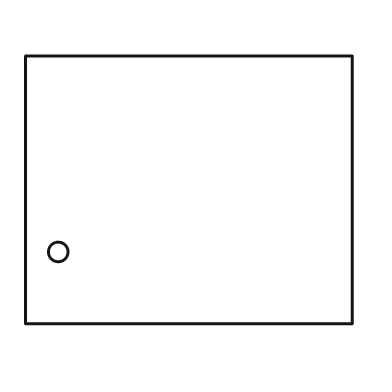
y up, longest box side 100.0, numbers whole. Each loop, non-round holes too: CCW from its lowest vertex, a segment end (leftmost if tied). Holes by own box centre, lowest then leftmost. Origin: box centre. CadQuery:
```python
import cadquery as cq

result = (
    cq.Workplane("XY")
    .moveTo(-50.0, -41.0)
    .lineTo(50.0, -41.0)
    .lineTo(50.0, 41.0)
    .lineTo(-50.0, 41.0)
    .close()
    .moveTo(-40.0, -19.0)
    .circle(3.0)
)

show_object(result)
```